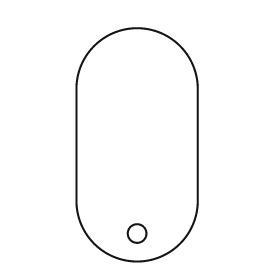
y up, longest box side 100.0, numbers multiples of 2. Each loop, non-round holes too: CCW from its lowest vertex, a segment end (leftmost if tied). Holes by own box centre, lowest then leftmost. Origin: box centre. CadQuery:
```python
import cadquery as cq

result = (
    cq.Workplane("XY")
    .moveTo(-26.0, -24.0)
    .threePointArc((0.0, -50.0), (26.0, -24.0))
    .lineTo(26.0, 24.0)
    .threePointArc((0.0, 50.0), (-26.0, 24.0))
    .close()
    .moveTo(0.0, -38.0)
    .circle(4.0)
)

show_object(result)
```